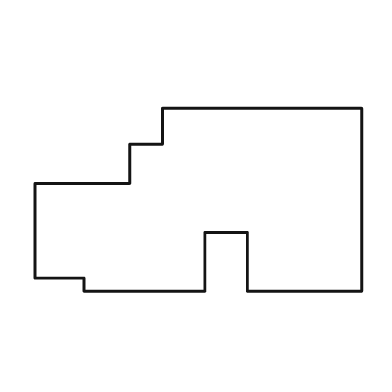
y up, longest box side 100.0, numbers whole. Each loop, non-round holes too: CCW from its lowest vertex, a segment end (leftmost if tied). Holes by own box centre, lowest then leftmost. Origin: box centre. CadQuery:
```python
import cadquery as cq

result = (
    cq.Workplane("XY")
    .moveTo(-35.0, -28.0)
    .lineTo(2.0, -28.0)
    .lineTo(2.0, -10.0)
    .lineTo(15.0, -10.0)
    .lineTo(15.0, -28.0)
    .lineTo(50.0, -28.0)
    .lineTo(50.0, 28.0)
    .lineTo(-11.0, 28.0)
    .lineTo(-11.0, 17.0)
    .lineTo(-21.0, 17.0)
    .lineTo(-21.0, 5.0)
    .lineTo(-50.0, 5.0)
    .lineTo(-50.0, -24.0)
    .lineTo(-35.0, -24.0)
    .close()
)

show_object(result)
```